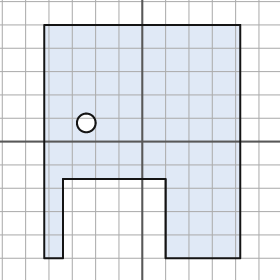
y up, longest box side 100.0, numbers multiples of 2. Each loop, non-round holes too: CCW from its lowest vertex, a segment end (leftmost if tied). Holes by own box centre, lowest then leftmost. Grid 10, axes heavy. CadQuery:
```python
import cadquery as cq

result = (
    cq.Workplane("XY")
    .moveTo(-42.0, -50.0)
    .lineTo(-34.0, -50.0)
    .lineTo(-34.0, -16.0)
    .lineTo(10.0, -16.0)
    .lineTo(10.0, -50.0)
    .lineTo(42.0, -50.0)
    .lineTo(42.0, 50.0)
    .lineTo(-42.0, 50.0)
    .close()
    .moveTo(-24.0, 8.0)
    .circle(4.0)
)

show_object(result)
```